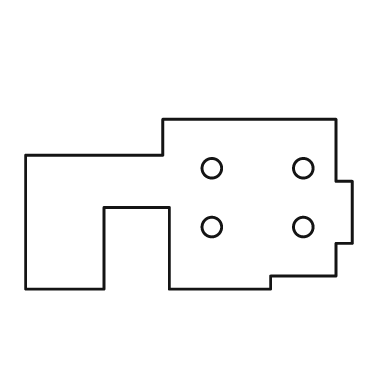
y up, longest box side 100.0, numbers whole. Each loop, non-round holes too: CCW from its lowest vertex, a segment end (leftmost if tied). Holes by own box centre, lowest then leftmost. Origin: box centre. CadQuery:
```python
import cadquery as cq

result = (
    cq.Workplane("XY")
    .moveTo(-50.0, -26.0)
    .lineTo(-26.0, -26.0)
    .lineTo(-26.0, -1.0)
    .lineTo(-6.0, -1.0)
    .lineTo(-6.0, -26.0)
    .lineTo(25.0, -26.0)
    .lineTo(25.0, -22.0)
    .lineTo(45.0, -22.0)
    .lineTo(45.0, -12.0)
    .lineTo(50.0, -12.0)
    .lineTo(50.0, 7.0)
    .lineTo(45.0, 7.0)
    .lineTo(45.0, 26.0)
    .lineTo(-8.0, 26.0)
    .lineTo(-8.0, 15.0)
    .lineTo(-50.0, 15.0)
    .close()
    .moveTo(7.0, -7.0)
    .circle(3.0)
    .moveTo(35.0, -7.0)
    .circle(3.0)
    .moveTo(7.0, 11.0)
    .circle(3.0)
    .moveTo(35.0, 11.0)
    .circle(3.0)
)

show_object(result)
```